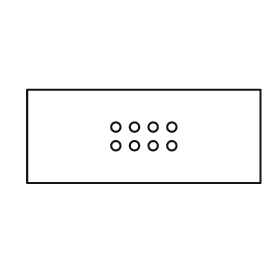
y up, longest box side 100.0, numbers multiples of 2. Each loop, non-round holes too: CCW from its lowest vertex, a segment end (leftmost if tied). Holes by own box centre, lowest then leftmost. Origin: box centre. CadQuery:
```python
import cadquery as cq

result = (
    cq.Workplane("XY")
    .moveTo(-50.0, -20.0)
    .lineTo(50.0, -20.0)
    .lineTo(50.0, 20.0)
    .lineTo(-50.0, 20.0)
    .close()
    .moveTo(-12.0, -4.0)
    .circle(2.0)
    .moveTo(-4.0, -4.0)
    .circle(2.0)
    .moveTo(4.0, -4.0)
    .circle(2.0)
    .moveTo(12.0, -4.0)
    .circle(2.0)
    .moveTo(-12.0, 4.0)
    .circle(2.0)
    .moveTo(-4.0, 4.0)
    .circle(2.0)
    .moveTo(4.0, 4.0)
    .circle(2.0)
    .moveTo(12.0, 4.0)
    .circle(2.0)
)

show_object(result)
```